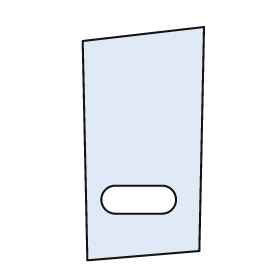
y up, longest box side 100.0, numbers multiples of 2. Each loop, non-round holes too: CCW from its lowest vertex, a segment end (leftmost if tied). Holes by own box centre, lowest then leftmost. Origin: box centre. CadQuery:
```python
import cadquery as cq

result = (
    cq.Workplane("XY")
    .moveTo(-24.0, -50.0)
    .lineTo(24.0, -46.0)
    .lineTo(26.0, 50.0)
    .lineTo(-26.0, 44.0)
    .close()
    .moveTo(-12.0, -30.0)
    .lineTo(8.0, -30.0)
    .threePointArc((14.0, -24.0), (8.0, -18.0))
    .lineTo(-12.0, -18.0)
    .threePointArc((-18.0, -24.0), (-12.0, -30.0))
    .close()
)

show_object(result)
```